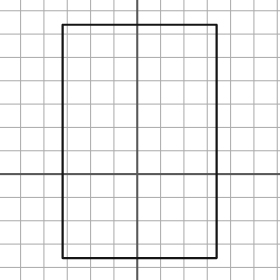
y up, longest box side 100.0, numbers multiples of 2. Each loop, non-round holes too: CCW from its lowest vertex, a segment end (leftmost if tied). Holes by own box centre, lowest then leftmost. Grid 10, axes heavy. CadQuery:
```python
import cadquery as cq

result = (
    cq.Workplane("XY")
    .moveTo(-32.0, -36.0)
    .lineTo(34.0, -36.0)
    .lineTo(34.0, 64.0)
    .lineTo(-32.0, 64.0)
    .close()
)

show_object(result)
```